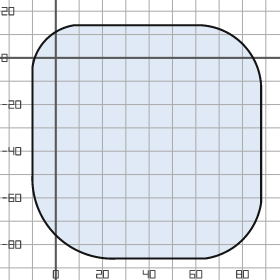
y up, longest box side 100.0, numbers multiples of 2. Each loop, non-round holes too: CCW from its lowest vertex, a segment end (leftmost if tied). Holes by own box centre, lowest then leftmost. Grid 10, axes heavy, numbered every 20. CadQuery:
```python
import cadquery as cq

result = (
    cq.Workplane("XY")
    .moveTo(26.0, -86.0)
    .lineTo(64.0, -86.0)
    .threePointArc((80.0, -78.0), (88.0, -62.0))
    .lineTo(88.0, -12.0)
    .threePointArc((80.0, 6.0), (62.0, 14.0))
    .lineTo(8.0, 14.0)
    .threePointArc((-4.0, 8.0), (-10.0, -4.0))
    .lineTo(-10.0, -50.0)
    .threePointArc((0.0, -76.0), (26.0, -86.0))
    .close()
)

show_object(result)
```